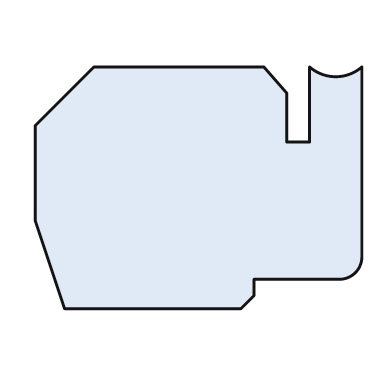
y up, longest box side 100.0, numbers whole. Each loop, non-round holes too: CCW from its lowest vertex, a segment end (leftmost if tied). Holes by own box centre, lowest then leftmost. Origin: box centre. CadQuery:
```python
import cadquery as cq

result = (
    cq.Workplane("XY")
    .moveTo(-41.0, -37.0)
    .lineTo(13.0, -37.0)
    .lineTo(17.0, -33.0)
    .lineTo(17.0, -28.0)
    .lineTo(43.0, -28.0)
    .threePointArc((48.0, -26.0), (50.0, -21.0))
    .lineTo(50.0, 37.0)
    .threePointArc((42.0, 34.0), (34.0, 37.0))
    .lineTo(34.0, 14.0)
    .lineTo(27.0, 14.0)
    .lineTo(27.0, 29.0)
    .lineTo(20.0, 37.0)
    .lineTo(-32.0, 37.0)
    .lineTo(-50.0, 19.0)
    .lineTo(-50.0, -10.0)
    .close()
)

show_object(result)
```